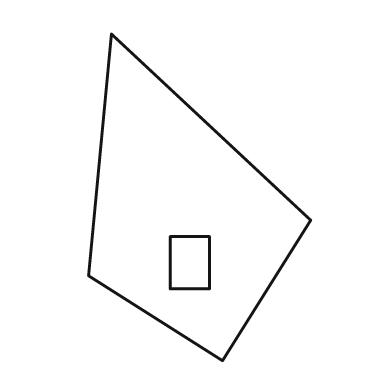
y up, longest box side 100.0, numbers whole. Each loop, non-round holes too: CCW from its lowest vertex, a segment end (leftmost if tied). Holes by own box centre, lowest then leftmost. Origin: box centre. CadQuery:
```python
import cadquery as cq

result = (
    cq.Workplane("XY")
    .moveTo(7.0, -50.0)
    .lineTo(34.0, -7.0)
    .lineTo(-27.0, 50.0)
    .lineTo(-34.0, -24.0)
    .close()
    .moveTo(-9.0, -28.0)
    .lineTo(3.0, -28.0)
    .lineTo(3.0, -12.0)
    .lineTo(-9.0, -12.0)
    .close()
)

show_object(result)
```